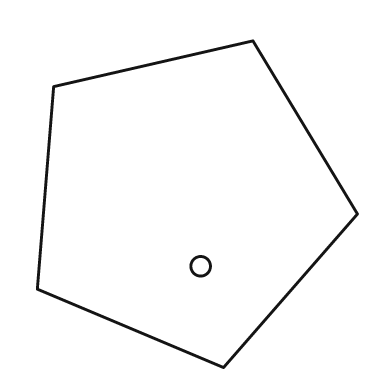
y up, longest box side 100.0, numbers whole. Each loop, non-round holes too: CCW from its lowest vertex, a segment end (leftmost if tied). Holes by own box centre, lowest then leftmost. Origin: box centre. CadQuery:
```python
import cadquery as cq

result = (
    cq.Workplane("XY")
    .moveTo(8.0, -50.0)
    .lineTo(49.0, -3.0)
    .lineTo(17.0, 50.0)
    .lineTo(-44.0, 36.0)
    .lineTo(-49.0, -26.0)
    .close()
    .moveTo(1.0, -19.0)
    .circle(3.0)
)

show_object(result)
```